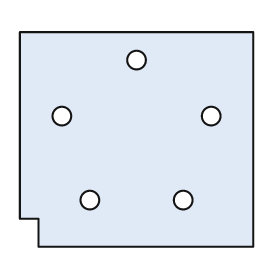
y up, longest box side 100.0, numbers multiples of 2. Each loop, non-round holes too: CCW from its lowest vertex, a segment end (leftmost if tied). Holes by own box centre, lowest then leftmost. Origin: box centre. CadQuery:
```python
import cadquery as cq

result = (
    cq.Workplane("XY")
    .moveTo(-42.0, -46.0)
    .lineTo(50.0, -46.0)
    .lineTo(50.0, 46.0)
    .lineTo(-50.0, 46.0)
    .lineTo(-50.0, -34.0)
    .lineTo(-42.0, -34.0)
    .close()
    .moveTo(-20.0, -26.0)
    .circle(4.0)
    .moveTo(20.0, -26.0)
    .circle(4.0)
    .moveTo(-32.0, 10.0)
    .circle(4.0)
    .moveTo(32.0, 10.0)
    .circle(4.0)
    .moveTo(0.0, 34.0)
    .circle(4.0)
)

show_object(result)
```